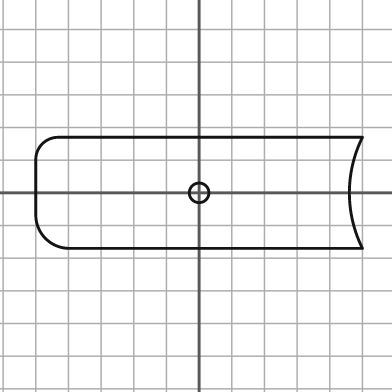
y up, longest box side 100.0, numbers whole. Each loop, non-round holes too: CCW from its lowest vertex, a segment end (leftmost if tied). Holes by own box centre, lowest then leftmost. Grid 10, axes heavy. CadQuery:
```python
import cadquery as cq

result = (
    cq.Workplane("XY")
    .moveTo(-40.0, -17.0)
    .lineTo(50.0, -17.0)
    .threePointArc((46.0, 0.0), (50.0, 17.0))
    .lineTo(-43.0, 17.0)
    .threePointArc((-48.0, 15.0), (-50.0, 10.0))
    .lineTo(-50.0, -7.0)
    .threePointArc((-47.0, -14.0), (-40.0, -17.0))
    .close()
    .moveTo(0.0, 0.0)
    .circle(3.0)
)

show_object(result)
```